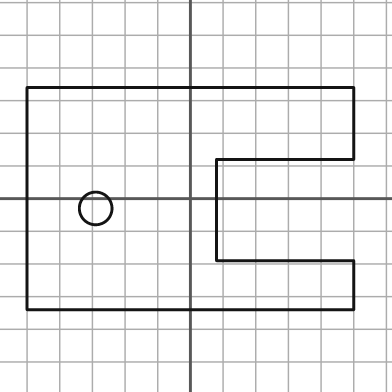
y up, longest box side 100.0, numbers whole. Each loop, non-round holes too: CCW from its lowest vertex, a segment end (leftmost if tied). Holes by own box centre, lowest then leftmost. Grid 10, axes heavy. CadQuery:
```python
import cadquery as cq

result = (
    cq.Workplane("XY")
    .moveTo(-50.0, -34.0)
    .lineTo(50.0, -34.0)
    .lineTo(50.0, -19.0)
    .lineTo(8.0, -19.0)
    .lineTo(8.0, 12.0)
    .lineTo(50.0, 12.0)
    .lineTo(50.0, 34.0)
    .lineTo(-50.0, 34.0)
    .close()
    .moveTo(-29.0, -3.0)
    .circle(5.0)
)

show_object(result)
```